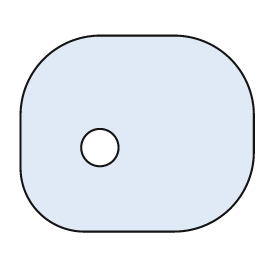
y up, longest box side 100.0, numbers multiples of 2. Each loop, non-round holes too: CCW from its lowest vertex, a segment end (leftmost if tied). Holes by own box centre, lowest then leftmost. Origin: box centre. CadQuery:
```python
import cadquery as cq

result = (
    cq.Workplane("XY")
    .moveTo(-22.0, -42.0)
    .lineTo(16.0, -42.0)
    .threePointArc((40.0, -32.0), (50.0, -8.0))
    .lineTo(50.0, 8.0)
    .threePointArc((40.0, 32.0), (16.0, 42.0))
    .lineTo(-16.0, 42.0)
    .threePointArc((-40.0, 32.0), (-50.0, 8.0))
    .lineTo(-50.0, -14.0)
    .threePointArc((-42.0, -34.0), (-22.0, -42.0))
    .close()
    .moveTo(-16.0, -6.0)
    .circle(8.0)
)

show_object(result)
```